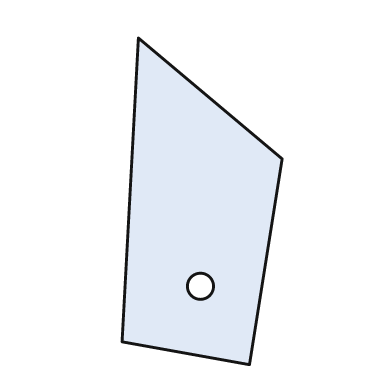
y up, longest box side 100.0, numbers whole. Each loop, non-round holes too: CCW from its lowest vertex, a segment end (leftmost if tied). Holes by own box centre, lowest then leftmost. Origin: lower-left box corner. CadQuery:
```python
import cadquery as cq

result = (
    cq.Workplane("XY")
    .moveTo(39.0, 0.0)
    .lineTo(49.0, 63.0)
    .lineTo(5.0, 100.0)
    .lineTo(0.0, 7.0)
    .close()
    .moveTo(24.0, 24.0)
    .circle(4.0)
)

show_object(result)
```